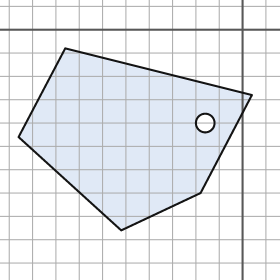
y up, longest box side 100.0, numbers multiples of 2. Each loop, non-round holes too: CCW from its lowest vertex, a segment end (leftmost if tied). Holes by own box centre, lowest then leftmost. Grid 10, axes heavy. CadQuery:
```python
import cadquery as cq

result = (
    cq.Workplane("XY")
    .moveTo(-52.0, -86.0)
    .lineTo(-18.0, -70.0)
    .lineTo(4.0, -28.0)
    .lineTo(-76.0, -8.0)
    .lineTo(-96.0, -46.0)
    .close()
    .moveTo(-16.0, -40.0)
    .circle(4.0)
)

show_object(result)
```